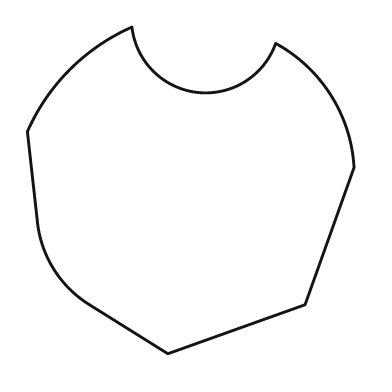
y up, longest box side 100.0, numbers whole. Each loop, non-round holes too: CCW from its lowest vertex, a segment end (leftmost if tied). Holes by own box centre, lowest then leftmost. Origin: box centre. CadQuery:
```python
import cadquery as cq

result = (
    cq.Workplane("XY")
    .moveTo(-7.0, -50.0)
    .lineTo(35.0, -35.0)
    .lineTo(50.0, 7.0)
    .threePointArc((43.0, 29.0), (26.0, 45.0))
    .threePointArc((2.0, 30.0), (-18.0, 50.0))
    .threePointArc((-37.0, 37.0), (-50.0, 18.0))
    .lineTo(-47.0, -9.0)
    .threePointArc((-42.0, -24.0), (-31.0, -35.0))
    .close()
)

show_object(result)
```